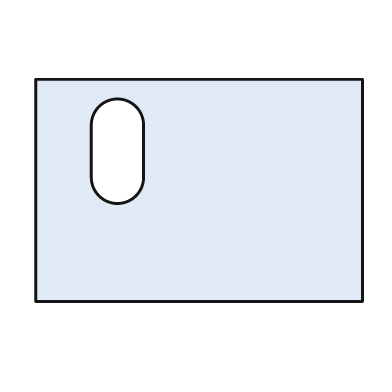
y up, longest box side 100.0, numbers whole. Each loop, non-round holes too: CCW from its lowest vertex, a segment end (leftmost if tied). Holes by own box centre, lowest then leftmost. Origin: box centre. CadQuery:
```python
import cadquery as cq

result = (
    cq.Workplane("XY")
    .moveTo(-50.0, -34.0)
    .lineTo(50.0, -34.0)
    .lineTo(50.0, 34.0)
    .lineTo(-50.0, 34.0)
    .close()
    .moveTo(-33.0, 4.0)
    .threePointArc((-25.0, -4.0), (-17.0, 4.0))
    .lineTo(-17.0, 20.0)
    .threePointArc((-25.0, 28.0), (-33.0, 20.0))
    .close()
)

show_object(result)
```